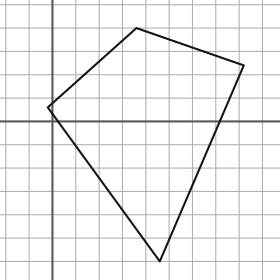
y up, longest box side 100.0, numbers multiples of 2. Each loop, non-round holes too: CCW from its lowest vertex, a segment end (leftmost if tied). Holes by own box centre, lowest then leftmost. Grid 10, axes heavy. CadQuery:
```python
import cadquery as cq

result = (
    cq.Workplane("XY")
    .moveTo(46.0, -60.0)
    .lineTo(82.0, 24.0)
    .lineTo(36.0, 40.0)
    .lineTo(-2.0, 6.0)
    .close()
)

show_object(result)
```